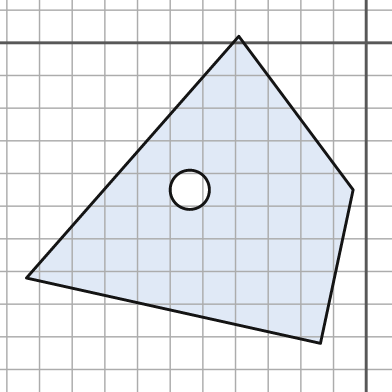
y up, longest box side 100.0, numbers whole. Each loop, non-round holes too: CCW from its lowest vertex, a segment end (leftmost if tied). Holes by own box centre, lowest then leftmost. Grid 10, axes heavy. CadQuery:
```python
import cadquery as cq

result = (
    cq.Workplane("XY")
    .moveTo(-14.0, -92.0)
    .lineTo(-4.0, -45.0)
    .lineTo(-39.0, 2.0)
    .lineTo(-104.0, -72.0)
    .close()
    .moveTo(-54.0, -45.0)
    .circle(6.0)
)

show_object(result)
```